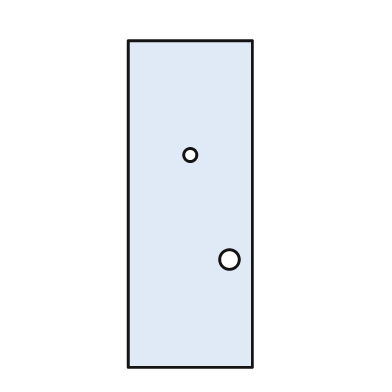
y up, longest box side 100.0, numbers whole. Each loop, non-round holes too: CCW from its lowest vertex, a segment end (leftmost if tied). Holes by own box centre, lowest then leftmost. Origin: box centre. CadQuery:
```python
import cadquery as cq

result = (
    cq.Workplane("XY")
    .moveTo(-19.0, -50.0)
    .lineTo(19.0, -50.0)
    .lineTo(19.0, 50.0)
    .lineTo(-19.0, 50.0)
    .close()
    .moveTo(12.0, -17.0)
    .circle(3.0)
    .moveTo(0.0, 15.0)
    .circle(2.0)
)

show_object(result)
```